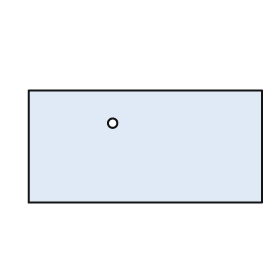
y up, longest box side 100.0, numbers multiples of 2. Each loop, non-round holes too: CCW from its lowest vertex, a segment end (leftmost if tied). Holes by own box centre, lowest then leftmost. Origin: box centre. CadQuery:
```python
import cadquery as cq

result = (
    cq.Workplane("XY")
    .moveTo(-50.0, -24.0)
    .lineTo(50.0, -24.0)
    .lineTo(50.0, 24.0)
    .lineTo(-50.0, 24.0)
    .close()
    .moveTo(-14.0, 10.0)
    .circle(2.0)
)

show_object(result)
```